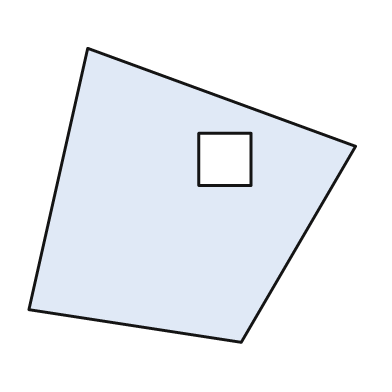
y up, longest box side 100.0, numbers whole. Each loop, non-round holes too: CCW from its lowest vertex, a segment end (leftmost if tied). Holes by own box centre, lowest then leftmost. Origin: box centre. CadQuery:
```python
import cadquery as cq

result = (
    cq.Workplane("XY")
    .moveTo(15.0, -45.0)
    .lineTo(50.0, 15.0)
    .lineTo(-32.0, 45.0)
    .lineTo(-50.0, -35.0)
    .close()
    .moveTo(2.0, 3.0)
    .lineTo(18.0, 3.0)
    .lineTo(18.0, 19.0)
    .lineTo(2.0, 19.0)
    .close()
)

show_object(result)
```